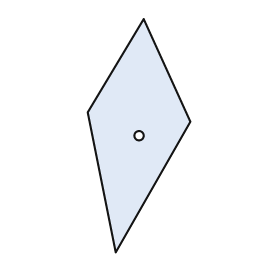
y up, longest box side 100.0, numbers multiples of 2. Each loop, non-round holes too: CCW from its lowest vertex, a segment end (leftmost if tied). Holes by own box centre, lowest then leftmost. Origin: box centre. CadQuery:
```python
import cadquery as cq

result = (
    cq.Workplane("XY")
    .moveTo(-10.0, -50.0)
    .lineTo(22.0, 6.0)
    .lineTo(2.0, 50.0)
    .lineTo(-22.0, 10.0)
    .close()
    .moveTo(0.0, 0.0)
    .circle(2.0)
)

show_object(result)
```